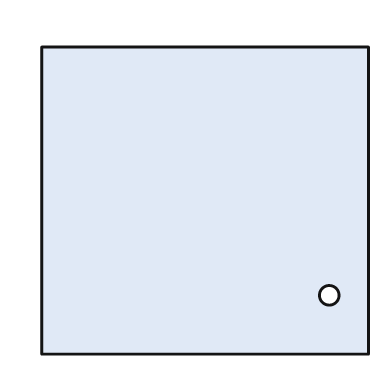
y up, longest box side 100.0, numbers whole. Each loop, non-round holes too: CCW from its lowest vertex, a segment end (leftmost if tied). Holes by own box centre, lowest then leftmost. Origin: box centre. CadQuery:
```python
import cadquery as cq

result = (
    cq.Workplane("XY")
    .moveTo(-50.0, -47.0)
    .lineTo(50.0, -47.0)
    .lineTo(50.0, 47.0)
    .lineTo(-50.0, 47.0)
    .close()
    .moveTo(38.0, -29.0)
    .circle(3.0)
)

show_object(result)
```